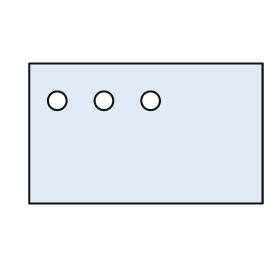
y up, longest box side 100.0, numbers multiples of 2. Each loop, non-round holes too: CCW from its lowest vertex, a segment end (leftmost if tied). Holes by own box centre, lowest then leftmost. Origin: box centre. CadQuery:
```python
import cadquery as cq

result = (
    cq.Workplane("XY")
    .moveTo(-50.0, -30.0)
    .lineTo(50.0, -30.0)
    .lineTo(50.0, 30.0)
    .lineTo(-50.0, 30.0)
    .close()
    .moveTo(-38.0, 14.0)
    .circle(4.0)
    .moveTo(-18.0, 14.0)
    .circle(4.0)
    .moveTo(2.0, 14.0)
    .circle(4.0)
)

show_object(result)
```